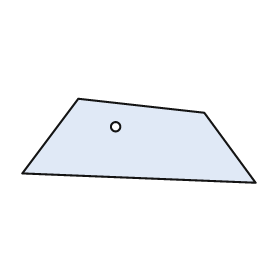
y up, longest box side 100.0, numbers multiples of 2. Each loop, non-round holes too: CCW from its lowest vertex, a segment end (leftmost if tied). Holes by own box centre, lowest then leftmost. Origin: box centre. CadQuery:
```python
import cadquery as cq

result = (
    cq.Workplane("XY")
    .moveTo(50.0, -18.0)
    .lineTo(28.0, 12.0)
    .lineTo(-26.0, 18.0)
    .lineTo(-50.0, -14.0)
    .close()
    .moveTo(-10.0, 6.0)
    .circle(2.0)
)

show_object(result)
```